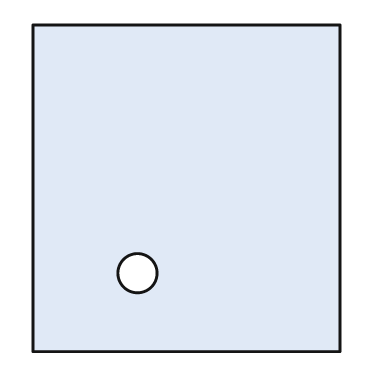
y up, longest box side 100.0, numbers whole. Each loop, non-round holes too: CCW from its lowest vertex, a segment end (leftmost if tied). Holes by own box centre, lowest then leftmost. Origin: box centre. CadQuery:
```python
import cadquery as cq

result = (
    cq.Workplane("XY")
    .moveTo(-47.0, -50.0)
    .lineTo(47.0, -50.0)
    .lineTo(47.0, 50.0)
    .lineTo(-47.0, 50.0)
    .close()
    .moveTo(-15.0, -26.0)
    .circle(6.0)
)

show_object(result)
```